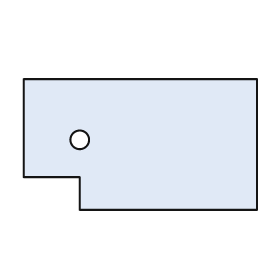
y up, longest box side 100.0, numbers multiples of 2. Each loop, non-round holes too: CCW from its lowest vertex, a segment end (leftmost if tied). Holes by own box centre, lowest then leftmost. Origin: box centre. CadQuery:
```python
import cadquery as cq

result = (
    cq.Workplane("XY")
    .moveTo(-26.0, -28.0)
    .lineTo(50.0, -28.0)
    .lineTo(50.0, 28.0)
    .lineTo(-50.0, 28.0)
    .lineTo(-50.0, -14.0)
    .lineTo(-26.0, -14.0)
    .close()
    .moveTo(-26.0, 2.0)
    .circle(4.0)
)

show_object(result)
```